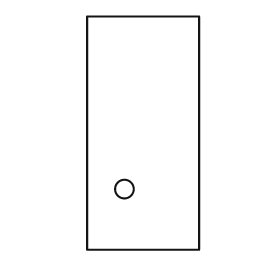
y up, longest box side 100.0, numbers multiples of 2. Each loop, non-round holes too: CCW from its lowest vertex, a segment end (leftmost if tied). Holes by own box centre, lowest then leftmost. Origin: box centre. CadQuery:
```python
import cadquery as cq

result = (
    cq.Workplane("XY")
    .moveTo(-24.0, -50.0)
    .lineTo(24.0, -50.0)
    .lineTo(24.0, 50.0)
    .lineTo(-24.0, 50.0)
    .close()
    .moveTo(-8.0, -24.0)
    .circle(4.0)
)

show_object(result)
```